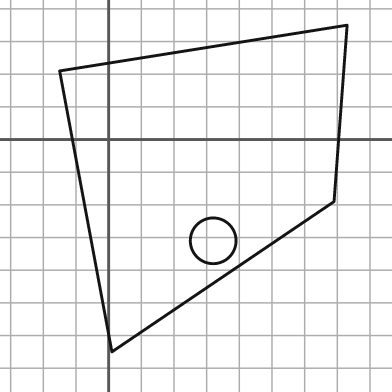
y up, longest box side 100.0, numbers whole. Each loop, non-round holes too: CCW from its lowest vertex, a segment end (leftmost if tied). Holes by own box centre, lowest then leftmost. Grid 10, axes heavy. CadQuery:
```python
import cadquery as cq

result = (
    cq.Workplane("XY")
    .moveTo(1.0, -65.0)
    .lineTo(69.0, -19.0)
    .lineTo(73.0, 35.0)
    .lineTo(-15.0, 21.0)
    .close()
    .moveTo(32.0, -31.0)
    .circle(7.0)
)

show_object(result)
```